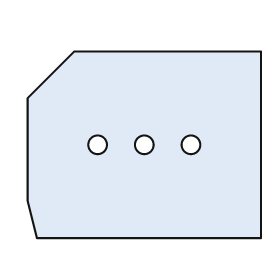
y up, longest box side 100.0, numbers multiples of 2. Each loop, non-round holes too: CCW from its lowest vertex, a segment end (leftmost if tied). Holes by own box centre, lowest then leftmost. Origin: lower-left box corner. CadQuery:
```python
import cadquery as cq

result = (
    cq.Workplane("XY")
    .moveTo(4.0, 0.0)
    .lineTo(100.0, 0.0)
    .lineTo(100.0, 80.0)
    .lineTo(20.0, 80.0)
    .lineTo(0.0, 60.0)
    .lineTo(0.0, 16.0)
    .close()
    .moveTo(30.0, 40.0)
    .circle(4.0)
    .moveTo(50.0, 40.0)
    .circle(4.0)
    .moveTo(70.0, 40.0)
    .circle(4.0)
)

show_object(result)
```